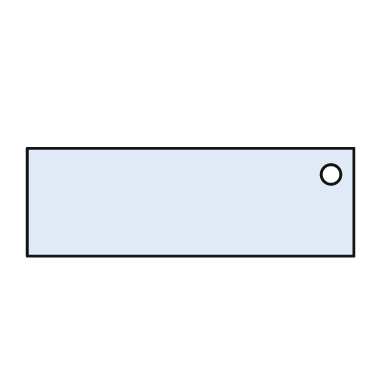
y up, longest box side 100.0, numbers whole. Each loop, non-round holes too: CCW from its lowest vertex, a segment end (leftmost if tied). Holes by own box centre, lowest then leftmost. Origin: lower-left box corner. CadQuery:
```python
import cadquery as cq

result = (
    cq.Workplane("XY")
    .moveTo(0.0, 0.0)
    .lineTo(100.0, 0.0)
    .lineTo(100.0, 33.0)
    .lineTo(0.0, 33.0)
    .close()
    .moveTo(93.0, 25.0)
    .circle(3.0)
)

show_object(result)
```